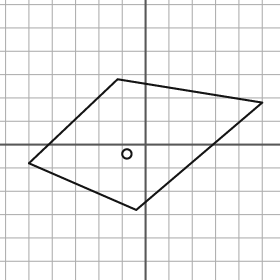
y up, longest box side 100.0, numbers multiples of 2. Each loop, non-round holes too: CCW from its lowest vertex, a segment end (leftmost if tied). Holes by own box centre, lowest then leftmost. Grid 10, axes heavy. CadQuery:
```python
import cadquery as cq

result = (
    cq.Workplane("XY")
    .moveTo(-4.0, -28.0)
    .lineTo(50.0, 18.0)
    .lineTo(-12.0, 28.0)
    .lineTo(-50.0, -8.0)
    .close()
    .moveTo(-8.0, -4.0)
    .circle(2.0)
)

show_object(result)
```